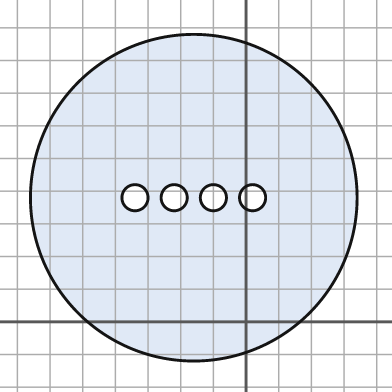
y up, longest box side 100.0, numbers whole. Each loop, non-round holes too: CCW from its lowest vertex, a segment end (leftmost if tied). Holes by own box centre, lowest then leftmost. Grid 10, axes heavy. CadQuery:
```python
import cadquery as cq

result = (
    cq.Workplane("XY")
    .moveTo(-16.0, 38.0)
    .circle(50.0)
    .moveTo(-34.0, 38.0)
    .circle(4.0)
    .moveTo(-22.0, 38.0)
    .circle(4.0)
    .moveTo(-10.0, 38.0)
    .circle(4.0)
    .moveTo(2.0, 38.0)
    .circle(4.0)
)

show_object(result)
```